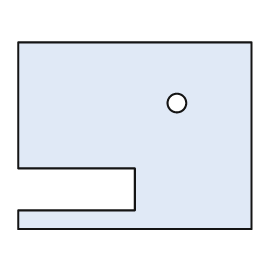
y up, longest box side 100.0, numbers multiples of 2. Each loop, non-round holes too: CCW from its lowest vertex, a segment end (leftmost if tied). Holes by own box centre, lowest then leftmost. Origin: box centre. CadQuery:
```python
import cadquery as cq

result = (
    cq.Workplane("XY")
    .moveTo(-50.0, -40.0)
    .lineTo(50.0, -40.0)
    .lineTo(50.0, 40.0)
    .lineTo(-50.0, 40.0)
    .lineTo(-50.0, -14.0)
    .lineTo(0.0, -14.0)
    .lineTo(0.0, -32.0)
    .lineTo(-50.0, -32.0)
    .close()
    .moveTo(18.0, 14.0)
    .circle(4.0)
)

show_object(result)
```